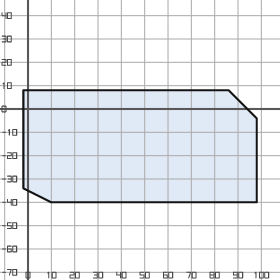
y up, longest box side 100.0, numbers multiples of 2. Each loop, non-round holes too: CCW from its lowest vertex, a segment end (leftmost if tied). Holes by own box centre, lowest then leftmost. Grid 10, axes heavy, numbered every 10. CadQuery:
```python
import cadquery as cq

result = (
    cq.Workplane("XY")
    .moveTo(10.0, -40.0)
    .lineTo(98.0, -40.0)
    .lineTo(98.0, -4.0)
    .lineTo(86.0, 8.0)
    .lineTo(-2.0, 8.0)
    .lineTo(-2.0, -34.0)
    .close()
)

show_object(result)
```